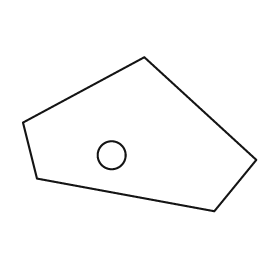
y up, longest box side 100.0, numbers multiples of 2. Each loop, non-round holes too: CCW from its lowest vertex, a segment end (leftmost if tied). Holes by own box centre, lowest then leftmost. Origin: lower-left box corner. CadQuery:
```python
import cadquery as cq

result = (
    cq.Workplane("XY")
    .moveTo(82.0, 0.0)
    .lineTo(100.0, 22.0)
    .lineTo(52.0, 66.0)
    .lineTo(0.0, 38.0)
    .lineTo(6.0, 14.0)
    .close()
    .moveTo(38.0, 24.0)
    .circle(6.0)
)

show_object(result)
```